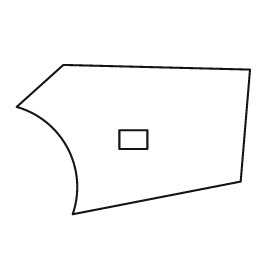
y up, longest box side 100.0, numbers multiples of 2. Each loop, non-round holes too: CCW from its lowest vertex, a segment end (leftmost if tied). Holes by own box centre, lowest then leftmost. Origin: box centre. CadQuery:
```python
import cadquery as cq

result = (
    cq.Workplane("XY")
    .moveTo(-26.0, -32.0)
    .lineTo(46.0, -18.0)
    .lineTo(50.0, 30.0)
    .lineTo(-30.0, 32.0)
    .lineTo(-50.0, 14.0)
    .threePointArc((-28.0, -4.0), (-26.0, -32.0))
    .close()
    .moveTo(-6.0, -4.0)
    .lineTo(6.0, -4.0)
    .lineTo(6.0, 4.0)
    .lineTo(-6.0, 4.0)
    .close()
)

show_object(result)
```